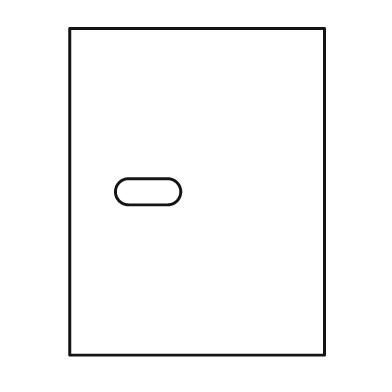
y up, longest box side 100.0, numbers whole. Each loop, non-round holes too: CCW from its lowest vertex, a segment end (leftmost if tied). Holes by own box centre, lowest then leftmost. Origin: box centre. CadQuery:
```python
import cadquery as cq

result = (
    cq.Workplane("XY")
    .moveTo(-39.0, -50.0)
    .lineTo(39.0, -50.0)
    .lineTo(39.0, 50.0)
    .lineTo(-39.0, 50.0)
    .close()
    .moveTo(-21.0, -4.0)
    .lineTo(-9.0, -4.0)
    .threePointArc((-5.0, 0.0), (-9.0, 4.0))
    .lineTo(-21.0, 4.0)
    .threePointArc((-25.0, 0.0), (-21.0, -4.0))
    .close()
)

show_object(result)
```